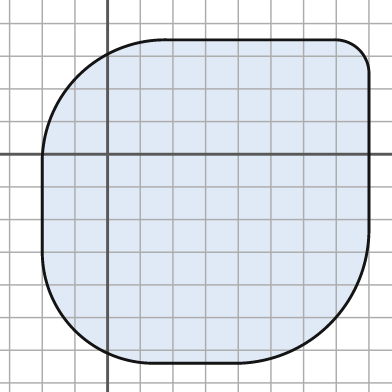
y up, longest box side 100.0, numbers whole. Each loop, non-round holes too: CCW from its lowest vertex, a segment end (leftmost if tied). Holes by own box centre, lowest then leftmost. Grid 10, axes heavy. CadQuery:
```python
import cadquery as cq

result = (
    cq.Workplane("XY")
    .moveTo(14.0, -64.0)
    .lineTo(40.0, -64.0)
    .threePointArc((68.0, -52.0), (80.0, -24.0))
    .lineTo(80.0, 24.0)
    .threePointArc((77.0, 32.0), (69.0, 35.0))
    .lineTo(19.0, 35.0)
    .threePointArc((-9.0, 24.0), (-20.0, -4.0))
    .lineTo(-20.0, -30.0)
    .threePointArc((-10.0, -54.0), (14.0, -64.0))
    .close()
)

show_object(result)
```